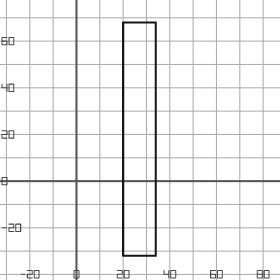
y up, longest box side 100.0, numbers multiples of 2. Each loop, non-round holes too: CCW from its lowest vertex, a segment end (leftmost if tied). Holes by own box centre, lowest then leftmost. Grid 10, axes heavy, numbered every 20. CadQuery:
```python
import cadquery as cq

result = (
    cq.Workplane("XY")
    .moveTo(20.0, -32.0)
    .lineTo(34.0, -32.0)
    .lineTo(34.0, 68.0)
    .lineTo(20.0, 68.0)
    .close()
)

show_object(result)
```